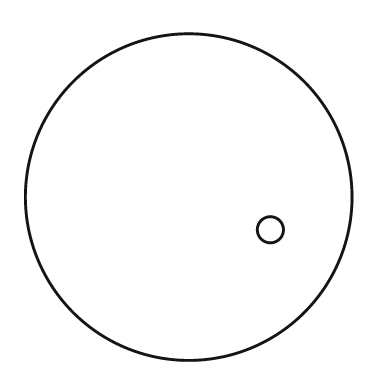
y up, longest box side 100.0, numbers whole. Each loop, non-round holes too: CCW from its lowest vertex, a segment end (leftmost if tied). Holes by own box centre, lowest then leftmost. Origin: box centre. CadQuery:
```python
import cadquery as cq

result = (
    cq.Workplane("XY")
    .moveTo(0.0, 0.0)
    .circle(50.0)
    .moveTo(25.0, -10.0)
    .circle(4.0)
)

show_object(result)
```